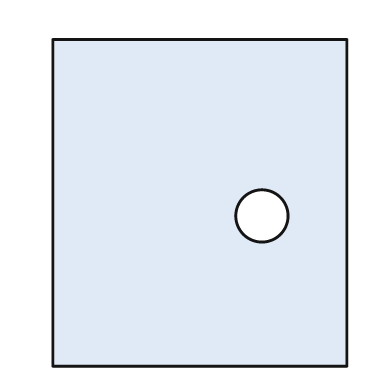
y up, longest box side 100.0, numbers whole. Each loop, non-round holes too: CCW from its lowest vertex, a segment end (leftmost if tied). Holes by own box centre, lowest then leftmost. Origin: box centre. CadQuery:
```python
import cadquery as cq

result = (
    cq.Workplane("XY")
    .moveTo(-45.0, -50.0)
    .lineTo(45.0, -50.0)
    .lineTo(45.0, 50.0)
    .lineTo(-45.0, 50.0)
    .close()
    .moveTo(19.0, -4.0)
    .circle(8.0)
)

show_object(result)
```